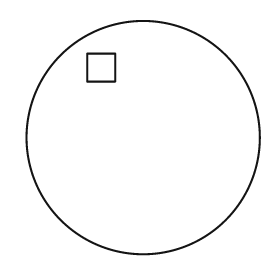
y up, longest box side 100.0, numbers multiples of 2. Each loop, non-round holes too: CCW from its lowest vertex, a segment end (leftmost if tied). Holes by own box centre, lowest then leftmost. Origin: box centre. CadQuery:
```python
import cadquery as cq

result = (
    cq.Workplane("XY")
    .moveTo(0.0, 0.0)
    .circle(50.0)
    .moveTo(-24.0, 24.0)
    .lineTo(-12.0, 24.0)
    .lineTo(-12.0, 36.0)
    .lineTo(-24.0, 36.0)
    .close()
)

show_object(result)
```